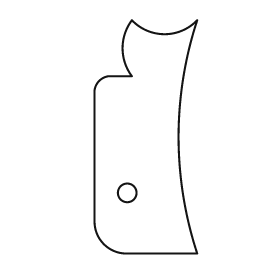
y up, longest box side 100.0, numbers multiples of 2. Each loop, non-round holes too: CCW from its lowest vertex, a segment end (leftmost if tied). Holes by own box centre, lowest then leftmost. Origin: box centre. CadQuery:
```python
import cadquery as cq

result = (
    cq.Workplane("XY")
    .moveTo(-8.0, -50.0)
    .lineTo(22.0, -50.0)
    .threePointArc((14.0, 0.0), (22.0, 50.0))
    .threePointArc((8.0, 44.0), (-6.0, 50.0))
    .threePointArc((-10.0, 38.0), (-6.0, 26.0))
    .lineTo(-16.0, 26.0)
    .threePointArc((-20.0, 24.0), (-22.0, 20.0))
    .lineTo(-22.0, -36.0)
    .threePointArc((-18.0, -46.0), (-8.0, -50.0))
    .close()
    .moveTo(-8.0, -24.0)
    .circle(4.0)
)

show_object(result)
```